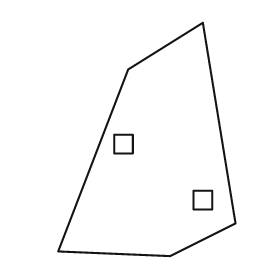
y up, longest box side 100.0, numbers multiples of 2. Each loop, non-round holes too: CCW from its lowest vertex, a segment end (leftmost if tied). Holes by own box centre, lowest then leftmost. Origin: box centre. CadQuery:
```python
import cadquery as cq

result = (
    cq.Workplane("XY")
    .moveTo(10.0, -50.0)
    .lineTo(38.0, -36.0)
    .lineTo(24.0, 50.0)
    .lineTo(-8.0, 30.0)
    .lineTo(-38.0, -48.0)
    .close()
    .moveTo(20.0, -30.0)
    .lineTo(28.0, -30.0)
    .lineTo(28.0, -22.0)
    .lineTo(20.0, -22.0)
    .close()
    .moveTo(-14.0, -6.0)
    .lineTo(-6.0, -6.0)
    .lineTo(-6.0, 2.0)
    .lineTo(-14.0, 2.0)
    .close()
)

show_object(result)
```